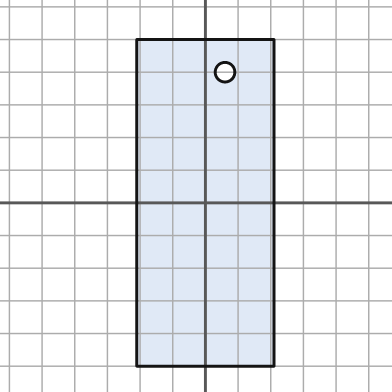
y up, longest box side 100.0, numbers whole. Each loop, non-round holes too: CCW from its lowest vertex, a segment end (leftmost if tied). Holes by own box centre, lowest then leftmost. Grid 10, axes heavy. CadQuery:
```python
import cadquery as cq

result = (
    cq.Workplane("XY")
    .moveTo(-21.0, -50.0)
    .lineTo(21.0, -50.0)
    .lineTo(21.0, 50.0)
    .lineTo(-21.0, 50.0)
    .close()
    .moveTo(6.0, 40.0)
    .circle(3.0)
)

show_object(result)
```